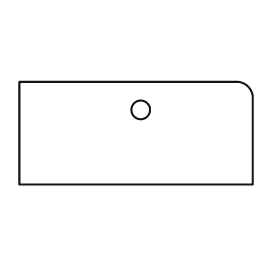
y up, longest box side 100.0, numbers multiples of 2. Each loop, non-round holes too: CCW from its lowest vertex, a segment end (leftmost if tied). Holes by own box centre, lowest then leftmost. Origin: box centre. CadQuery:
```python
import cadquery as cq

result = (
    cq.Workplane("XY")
    .moveTo(-50.0, -22.0)
    .lineTo(50.0, -22.0)
    .lineTo(50.0, 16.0)
    .threePointArc((48.0, 20.0), (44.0, 22.0))
    .lineTo(-50.0, 22.0)
    .close()
    .moveTo(2.0, 10.0)
    .circle(4.0)
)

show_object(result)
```